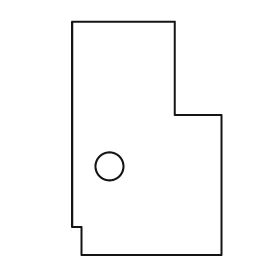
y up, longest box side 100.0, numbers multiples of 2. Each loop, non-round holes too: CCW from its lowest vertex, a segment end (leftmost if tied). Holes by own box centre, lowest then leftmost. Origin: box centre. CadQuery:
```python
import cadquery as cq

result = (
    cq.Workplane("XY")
    .moveTo(-28.0, -50.0)
    .lineTo(32.0, -50.0)
    .lineTo(32.0, 10.0)
    .lineTo(12.0, 10.0)
    .lineTo(12.0, 50.0)
    .lineTo(-32.0, 50.0)
    .lineTo(-32.0, -38.0)
    .lineTo(-28.0, -38.0)
    .close()
    .moveTo(-16.0, -12.0)
    .circle(6.0)
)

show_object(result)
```